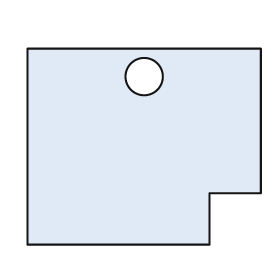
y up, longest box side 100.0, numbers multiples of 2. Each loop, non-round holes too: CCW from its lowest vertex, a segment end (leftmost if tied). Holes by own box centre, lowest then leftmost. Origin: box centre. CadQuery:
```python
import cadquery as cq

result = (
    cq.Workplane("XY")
    .moveTo(-50.0, -42.0)
    .lineTo(28.0, -42.0)
    .lineTo(28.0, -20.0)
    .lineTo(50.0, -20.0)
    .lineTo(50.0, 42.0)
    .lineTo(-50.0, 42.0)
    .close()
    .moveTo(0.0, 30.0)
    .circle(8.0)
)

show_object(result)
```